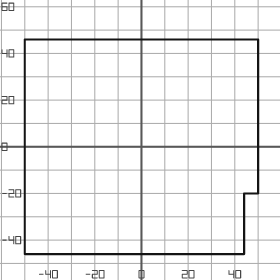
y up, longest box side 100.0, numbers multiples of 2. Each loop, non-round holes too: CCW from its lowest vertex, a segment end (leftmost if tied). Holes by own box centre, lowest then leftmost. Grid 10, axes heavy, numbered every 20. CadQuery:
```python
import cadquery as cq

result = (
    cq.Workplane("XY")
    .moveTo(-50.0, -46.0)
    .lineTo(44.0, -46.0)
    .lineTo(44.0, -20.0)
    .lineTo(50.0, -20.0)
    .lineTo(50.0, 46.0)
    .lineTo(-50.0, 46.0)
    .close()
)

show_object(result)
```